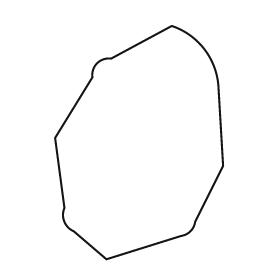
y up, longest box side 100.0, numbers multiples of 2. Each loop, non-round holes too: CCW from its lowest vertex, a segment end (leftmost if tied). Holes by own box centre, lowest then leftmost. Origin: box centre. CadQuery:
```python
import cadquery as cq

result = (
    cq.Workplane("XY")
    .moveTo(-14.0, -50.0)
    .lineTo(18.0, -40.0)
    .threePointArc((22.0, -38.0), (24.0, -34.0))
    .lineTo(36.0, -10.0)
    .lineTo(34.0, 24.0)
    .threePointArc((28.0, 40.0), (14.0, 50.0))
    .lineTo(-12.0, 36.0)
    .threePointArc((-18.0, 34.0), (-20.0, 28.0))
    .lineTo(-36.0, 2.0)
    .lineTo(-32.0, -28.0)
    .threePointArc((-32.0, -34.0), (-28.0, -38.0))
    .close()
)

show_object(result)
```